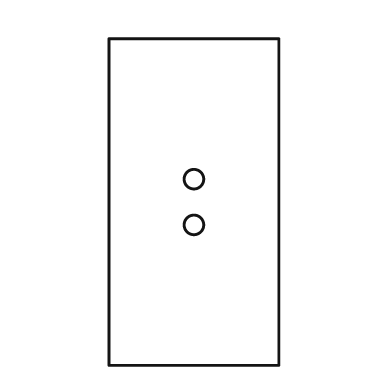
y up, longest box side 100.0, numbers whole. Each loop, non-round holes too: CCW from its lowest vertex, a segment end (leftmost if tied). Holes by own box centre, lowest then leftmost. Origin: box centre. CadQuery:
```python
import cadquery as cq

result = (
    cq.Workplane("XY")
    .moveTo(-26.0, -50.0)
    .lineTo(26.0, -50.0)
    .lineTo(26.0, 50.0)
    .lineTo(-26.0, 50.0)
    .close()
    .moveTo(0.0, -7.0)
    .circle(3.0)
    .moveTo(0.0, 7.0)
    .circle(3.0)
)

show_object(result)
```